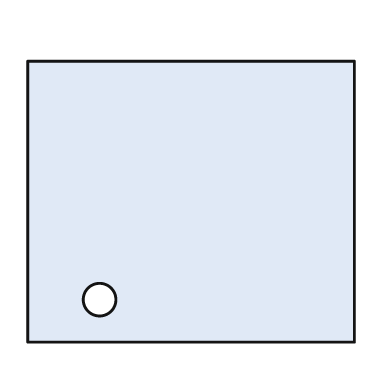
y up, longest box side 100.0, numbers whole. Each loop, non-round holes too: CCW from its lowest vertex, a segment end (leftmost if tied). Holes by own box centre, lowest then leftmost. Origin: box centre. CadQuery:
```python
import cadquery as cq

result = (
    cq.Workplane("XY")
    .moveTo(-50.0, -43.0)
    .lineTo(50.0, -43.0)
    .lineTo(50.0, 43.0)
    .lineTo(-50.0, 43.0)
    .close()
    .moveTo(-28.0, -30.0)
    .circle(5.0)
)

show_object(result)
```